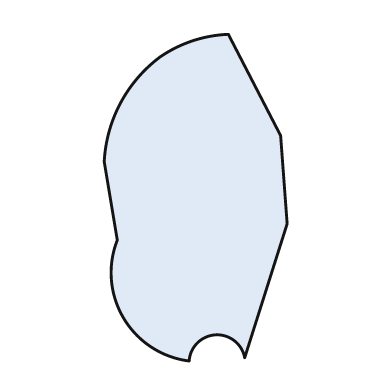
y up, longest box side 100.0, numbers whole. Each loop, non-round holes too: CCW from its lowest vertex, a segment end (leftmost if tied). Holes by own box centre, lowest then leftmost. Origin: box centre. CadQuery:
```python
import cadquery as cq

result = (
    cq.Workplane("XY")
    .moveTo(-2.0, -50.0)
    .threePointArc((6.0, -42.0), (15.0, -49.0))
    .lineTo(28.0, -8.0)
    .lineTo(26.0, 19.0)
    .lineTo(10.0, 50.0)
    .threePointArc((-1.0, 48.0), (-11.0, 43.0))
    .threePointArc((-23.0, 29.0), (-28.0, 11.0))
    .lineTo(-24.0, -13.0)
    .threePointArc((-22.0, -37.0), (-2.0, -50.0))
    .close()
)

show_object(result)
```